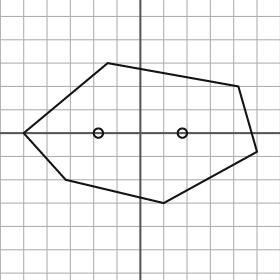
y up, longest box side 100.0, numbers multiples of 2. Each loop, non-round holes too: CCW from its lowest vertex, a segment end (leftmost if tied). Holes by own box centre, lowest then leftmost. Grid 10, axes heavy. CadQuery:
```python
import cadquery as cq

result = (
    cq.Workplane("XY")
    .moveTo(10.0, -30.0)
    .lineTo(50.0, -8.0)
    .lineTo(42.0, 20.0)
    .lineTo(-14.0, 30.0)
    .lineTo(-50.0, 0.0)
    .lineTo(-32.0, -20.0)
    .close()
    .moveTo(-18.0, 0.0)
    .circle(2.0)
    .moveTo(18.0, 0.0)
    .circle(2.0)
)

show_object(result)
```